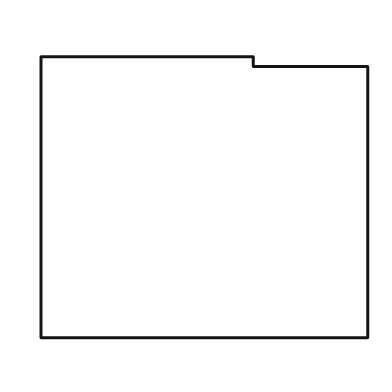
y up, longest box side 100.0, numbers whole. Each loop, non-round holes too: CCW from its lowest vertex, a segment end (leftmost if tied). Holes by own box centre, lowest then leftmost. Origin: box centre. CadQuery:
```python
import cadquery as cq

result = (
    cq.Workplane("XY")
    .moveTo(-50.0, -43.0)
    .lineTo(50.0, -43.0)
    .lineTo(50.0, 40.0)
    .lineTo(15.0, 40.0)
    .lineTo(15.0, 43.0)
    .lineTo(-50.0, 43.0)
    .close()
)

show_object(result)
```